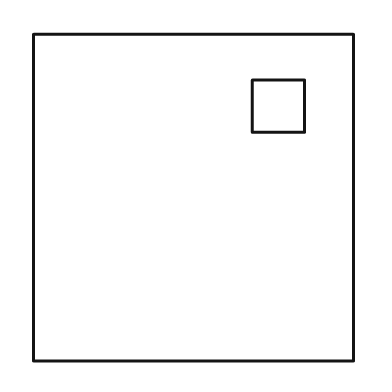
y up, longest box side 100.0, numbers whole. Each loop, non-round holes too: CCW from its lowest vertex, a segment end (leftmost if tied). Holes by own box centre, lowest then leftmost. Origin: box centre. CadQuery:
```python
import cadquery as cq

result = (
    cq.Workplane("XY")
    .moveTo(-49.0, -50.0)
    .lineTo(49.0, -50.0)
    .lineTo(49.0, 50.0)
    .lineTo(-49.0, 50.0)
    .close()
    .moveTo(18.0, 20.0)
    .lineTo(34.0, 20.0)
    .lineTo(34.0, 36.0)
    .lineTo(18.0, 36.0)
    .close()
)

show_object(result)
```